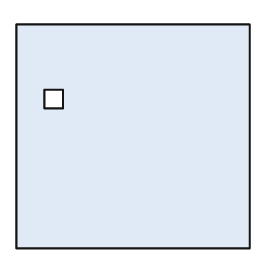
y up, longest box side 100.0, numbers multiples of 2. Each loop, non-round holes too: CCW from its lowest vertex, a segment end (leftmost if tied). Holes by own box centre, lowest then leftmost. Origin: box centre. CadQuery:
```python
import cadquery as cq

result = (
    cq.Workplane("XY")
    .moveTo(-50.0, -48.0)
    .lineTo(50.0, -48.0)
    .lineTo(50.0, 48.0)
    .lineTo(-50.0, 48.0)
    .close()
    .moveTo(-38.0, 12.0)
    .lineTo(-30.0, 12.0)
    .lineTo(-30.0, 20.0)
    .lineTo(-38.0, 20.0)
    .close()
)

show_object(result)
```